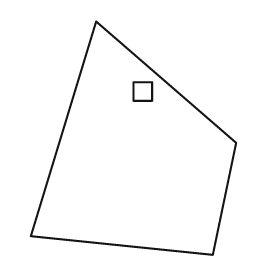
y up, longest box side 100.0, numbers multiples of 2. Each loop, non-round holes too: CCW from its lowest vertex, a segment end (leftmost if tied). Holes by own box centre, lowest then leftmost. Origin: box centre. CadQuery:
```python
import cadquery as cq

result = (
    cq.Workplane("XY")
    .moveTo(34.0, -50.0)
    .lineTo(44.0, -2.0)
    .lineTo(-16.0, 50.0)
    .lineTo(-44.0, -42.0)
    .close()
    .moveTo(0.0, 16.0)
    .lineTo(8.0, 16.0)
    .lineTo(8.0, 24.0)
    .lineTo(0.0, 24.0)
    .close()
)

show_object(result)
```